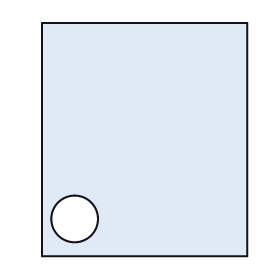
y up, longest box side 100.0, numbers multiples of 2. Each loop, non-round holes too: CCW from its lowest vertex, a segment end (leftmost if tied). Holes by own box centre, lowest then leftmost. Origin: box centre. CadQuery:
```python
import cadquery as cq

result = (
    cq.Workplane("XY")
    .moveTo(-44.0, -50.0)
    .lineTo(44.0, -50.0)
    .lineTo(44.0, 50.0)
    .lineTo(-44.0, 50.0)
    .close()
    .moveTo(-30.0, -34.0)
    .circle(10.0)
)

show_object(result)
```